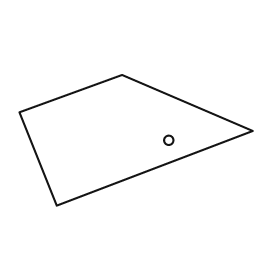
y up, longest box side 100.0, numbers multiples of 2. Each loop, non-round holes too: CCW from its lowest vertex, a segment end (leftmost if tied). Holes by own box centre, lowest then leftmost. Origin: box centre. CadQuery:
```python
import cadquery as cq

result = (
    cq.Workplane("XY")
    .moveTo(-34.0, -28.0)
    .lineTo(50.0, 4.0)
    .lineTo(-6.0, 28.0)
    .lineTo(-50.0, 12.0)
    .close()
    .moveTo(14.0, 0.0)
    .circle(2.0)
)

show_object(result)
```